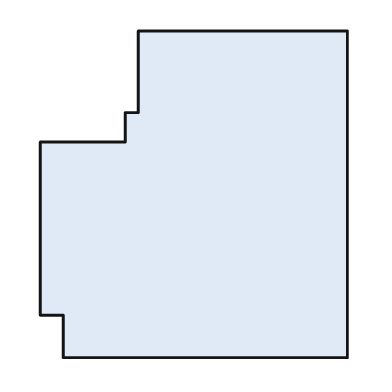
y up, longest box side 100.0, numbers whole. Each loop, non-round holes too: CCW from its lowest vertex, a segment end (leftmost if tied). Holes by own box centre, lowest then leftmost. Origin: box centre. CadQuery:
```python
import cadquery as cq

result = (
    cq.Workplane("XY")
    .moveTo(-40.0, -50.0)
    .lineTo(47.0, -50.0)
    .lineTo(47.0, 50.0)
    .lineTo(-17.0, 50.0)
    .lineTo(-17.0, 25.0)
    .lineTo(-21.0, 25.0)
    .lineTo(-21.0, 16.0)
    .lineTo(-47.0, 16.0)
    .lineTo(-47.0, -37.0)
    .lineTo(-40.0, -37.0)
    .close()
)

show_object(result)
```